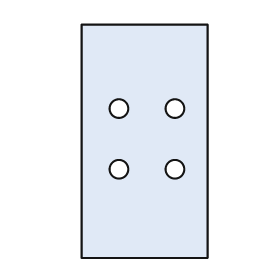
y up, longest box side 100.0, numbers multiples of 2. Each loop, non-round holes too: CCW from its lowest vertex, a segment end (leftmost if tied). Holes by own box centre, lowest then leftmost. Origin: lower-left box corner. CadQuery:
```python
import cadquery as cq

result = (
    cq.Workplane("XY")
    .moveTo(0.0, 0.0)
    .lineTo(54.0, 0.0)
    .lineTo(54.0, 100.0)
    .lineTo(0.0, 100.0)
    .close()
    .moveTo(16.0, 38.0)
    .circle(4.0)
    .moveTo(40.0, 38.0)
    .circle(4.0)
    .moveTo(16.0, 64.0)
    .circle(4.0)
    .moveTo(40.0, 64.0)
    .circle(4.0)
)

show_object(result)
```